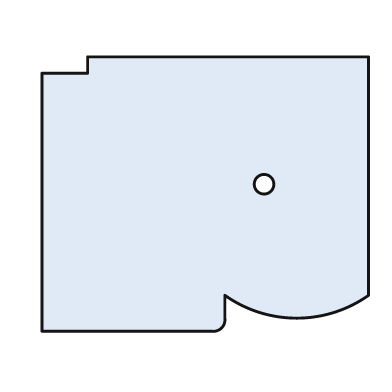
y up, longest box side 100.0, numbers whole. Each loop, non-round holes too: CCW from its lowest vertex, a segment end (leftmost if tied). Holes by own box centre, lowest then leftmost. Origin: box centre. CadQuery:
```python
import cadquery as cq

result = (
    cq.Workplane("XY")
    .moveTo(-50.0, -42.0)
    .lineTo(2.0, -42.0)
    .threePointArc((5.0, -41.0), (6.0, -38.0))
    .lineTo(6.0, -31.0)
    .threePointArc((28.0, -38.0), (50.0, -31.0))
    .lineTo(50.0, 42.0)
    .lineTo(-36.0, 42.0)
    .lineTo(-36.0, 37.0)
    .lineTo(-50.0, 37.0)
    .close()
    .moveTo(18.0, 3.0)
    .circle(3.0)
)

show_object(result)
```